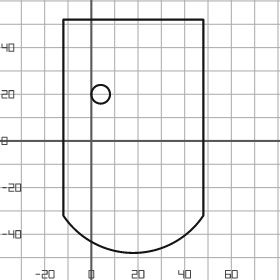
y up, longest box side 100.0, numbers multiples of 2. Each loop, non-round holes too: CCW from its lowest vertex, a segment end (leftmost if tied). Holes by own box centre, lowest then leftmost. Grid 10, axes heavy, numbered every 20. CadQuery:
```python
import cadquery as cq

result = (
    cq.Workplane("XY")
    .moveTo(-12.0, -32.0)
    .threePointArc((18.0, -48.0), (48.0, -32.0))
    .lineTo(48.0, 52.0)
    .lineTo(-12.0, 52.0)
    .close()
    .moveTo(4.0, 20.0)
    .circle(4.0)
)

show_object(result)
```